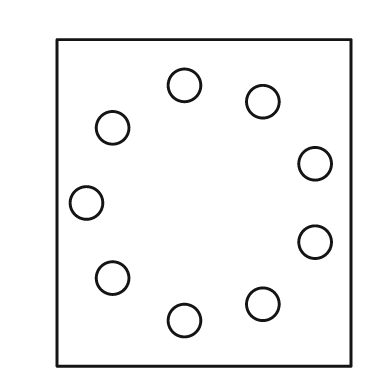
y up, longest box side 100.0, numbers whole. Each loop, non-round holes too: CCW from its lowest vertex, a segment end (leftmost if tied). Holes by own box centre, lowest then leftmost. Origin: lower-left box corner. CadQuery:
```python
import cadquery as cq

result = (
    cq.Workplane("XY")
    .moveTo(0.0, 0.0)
    .lineTo(90.0, 0.0)
    .lineTo(90.0, 100.0)
    .lineTo(0.0, 100.0)
    .close()
    .moveTo(39.0, 14.0)
    .circle(5.0)
    .moveTo(63.0, 19.0)
    .circle(5.0)
    .moveTo(17.0, 27.0)
    .circle(5.0)
    .moveTo(79.0, 38.0)
    .circle(5.0)
    .moveTo(9.0, 50.0)
    .circle(5.0)
    .moveTo(79.0, 62.0)
    .circle(5.0)
    .moveTo(17.0, 73.0)
    .circle(5.0)
    .moveTo(63.0, 81.0)
    .circle(5.0)
    .moveTo(39.0, 86.0)
    .circle(5.0)
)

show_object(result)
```